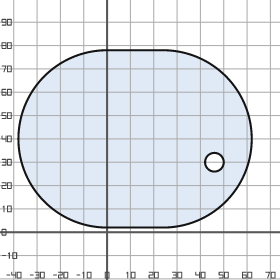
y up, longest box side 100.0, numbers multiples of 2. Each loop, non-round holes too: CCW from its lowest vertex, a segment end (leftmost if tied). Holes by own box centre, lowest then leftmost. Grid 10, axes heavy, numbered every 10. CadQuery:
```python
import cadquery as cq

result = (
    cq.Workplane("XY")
    .moveTo(0.0, 2.0)
    .lineTo(24.0, 2.0)
    .threePointArc((62.0, 40.0), (24.0, 78.0))
    .lineTo(0.0, 78.0)
    .threePointArc((-38.0, 40.0), (0.0, 2.0))
    .close()
    .moveTo(46.0, 30.0)
    .circle(4.0)
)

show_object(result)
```